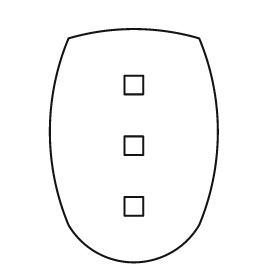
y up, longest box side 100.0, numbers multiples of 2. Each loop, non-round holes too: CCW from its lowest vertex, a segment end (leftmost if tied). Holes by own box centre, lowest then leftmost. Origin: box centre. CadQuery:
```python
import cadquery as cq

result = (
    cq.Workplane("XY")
    .moveTo(-28.0, -34.0)
    .threePointArc((0.0, -50.0), (28.0, -34.0))
    .threePointArc((36.0, 6.0), (28.0, 46.0))
    .threePointArc((0.0, 50.0), (-28.0, 46.0))
    .threePointArc((-36.0, 6.0), (-28.0, -34.0))
    .close()
    .moveTo(-4.0, -30.0)
    .lineTo(4.0, -30.0)
    .lineTo(4.0, -22.0)
    .lineTo(-4.0, -22.0)
    .close()
    .moveTo(-4.0, -4.0)
    .lineTo(4.0, -4.0)
    .lineTo(4.0, 4.0)
    .lineTo(-4.0, 4.0)
    .close()
    .moveTo(-4.0, 22.0)
    .lineTo(4.0, 22.0)
    .lineTo(4.0, 30.0)
    .lineTo(-4.0, 30.0)
    .close()
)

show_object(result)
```